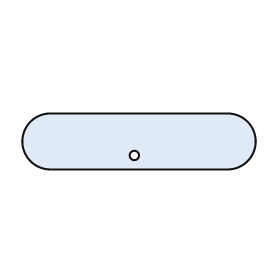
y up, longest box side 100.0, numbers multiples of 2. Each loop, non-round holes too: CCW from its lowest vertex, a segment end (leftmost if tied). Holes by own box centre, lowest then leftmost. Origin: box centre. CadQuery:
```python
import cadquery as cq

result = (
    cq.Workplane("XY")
    .moveTo(-38.0, -12.0)
    .lineTo(38.0, -12.0)
    .threePointArc((50.0, 0.0), (38.0, 12.0))
    .lineTo(-38.0, 12.0)
    .threePointArc((-50.0, 0.0), (-38.0, -12.0))
    .close()
    .moveTo(-2.0, -6.0)
    .circle(2.0)
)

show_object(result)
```